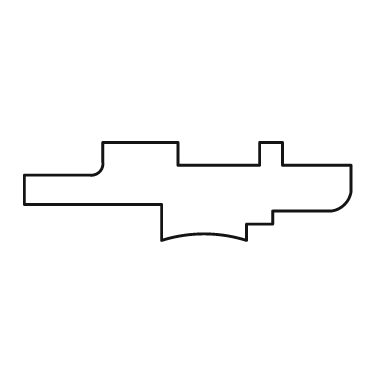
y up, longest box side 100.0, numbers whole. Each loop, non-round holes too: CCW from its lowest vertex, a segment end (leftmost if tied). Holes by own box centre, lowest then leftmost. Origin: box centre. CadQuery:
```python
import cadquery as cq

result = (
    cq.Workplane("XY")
    .moveTo(-8.0, -15.0)
    .threePointArc((5.0, -13.0), (18.0, -15.0))
    .lineTo(18.0, -10.0)
    .lineTo(26.0, -10.0)
    .lineTo(26.0, -6.0)
    .lineTo(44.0, -6.0)
    .threePointArc((48.0, -4.0), (50.0, 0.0))
    .lineTo(50.0, 8.0)
    .lineTo(29.0, 8.0)
    .lineTo(29.0, 15.0)
    .lineTo(22.0, 15.0)
    .lineTo(22.0, 8.0)
    .lineTo(-3.0, 8.0)
    .lineTo(-3.0, 15.0)
    .lineTo(-26.0, 15.0)
    .lineTo(-26.0, 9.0)
    .threePointArc((-27.0, 6.0), (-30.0, 5.0))
    .lineTo(-50.0, 5.0)
    .lineTo(-50.0, -4.0)
    .lineTo(-8.0, -4.0)
    .close()
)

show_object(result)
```